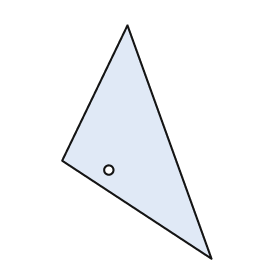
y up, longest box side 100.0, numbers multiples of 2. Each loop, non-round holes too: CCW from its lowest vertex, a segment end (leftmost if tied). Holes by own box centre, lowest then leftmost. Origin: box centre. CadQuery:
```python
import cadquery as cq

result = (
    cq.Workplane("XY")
    .moveTo(32.0, -50.0)
    .lineTo(-4.0, 50.0)
    .lineTo(-32.0, -8.0)
    .close()
    .moveTo(-12.0, -12.0)
    .circle(2.0)
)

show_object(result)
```